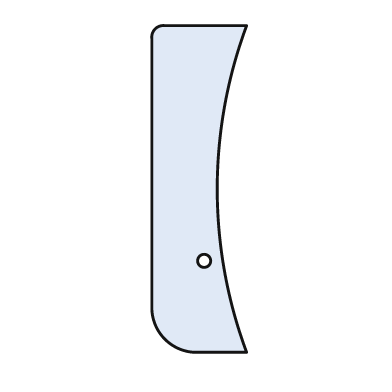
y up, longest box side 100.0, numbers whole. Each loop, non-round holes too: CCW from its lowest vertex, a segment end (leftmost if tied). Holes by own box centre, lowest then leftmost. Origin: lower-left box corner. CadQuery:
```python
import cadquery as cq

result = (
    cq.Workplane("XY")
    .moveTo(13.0, 0.0)
    .lineTo(29.0, 0.0)
    .threePointArc((20.0, 50.0), (29.0, 100.0))
    .lineTo(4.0, 100.0)
    .threePointArc((1.0, 99.0), (0.0, 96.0))
    .lineTo(0.0, 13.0)
    .threePointArc((4.0, 4.0), (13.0, 0.0))
    .close()
    .moveTo(16.0, 28.0)
    .circle(2.0)
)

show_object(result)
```